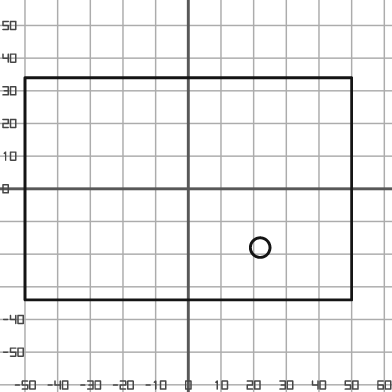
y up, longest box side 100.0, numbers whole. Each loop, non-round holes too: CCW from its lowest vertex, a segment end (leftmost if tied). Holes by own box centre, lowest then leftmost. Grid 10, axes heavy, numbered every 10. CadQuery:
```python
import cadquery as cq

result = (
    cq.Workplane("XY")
    .moveTo(-50.0, -34.0)
    .lineTo(50.0, -34.0)
    .lineTo(50.0, 34.0)
    .lineTo(-50.0, 34.0)
    .close()
    .moveTo(22.0, -18.0)
    .circle(3.0)
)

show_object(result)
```